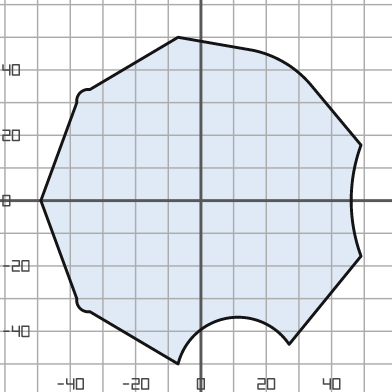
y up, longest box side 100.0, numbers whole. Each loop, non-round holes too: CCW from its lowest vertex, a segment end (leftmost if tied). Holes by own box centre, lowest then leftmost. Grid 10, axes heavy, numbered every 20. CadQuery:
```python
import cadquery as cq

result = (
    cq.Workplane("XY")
    .moveTo(-7.0, -50.0)
    .threePointArc((8.0, -36.0), (27.0, -44.0))
    .lineTo(49.0, -17.0)
    .threePointArc((46.0, 0.0), (49.0, 17.0))
    .lineTo(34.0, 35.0)
    .threePointArc((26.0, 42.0), (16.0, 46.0))
    .lineTo(-7.0, 50.0)
    .lineTo(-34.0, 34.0)
    .threePointArc((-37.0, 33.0), (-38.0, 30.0))
    .lineTo(-49.0, 0.0)
    .lineTo(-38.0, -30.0)
    .threePointArc((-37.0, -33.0), (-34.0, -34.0))
    .close()
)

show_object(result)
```